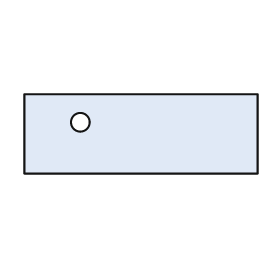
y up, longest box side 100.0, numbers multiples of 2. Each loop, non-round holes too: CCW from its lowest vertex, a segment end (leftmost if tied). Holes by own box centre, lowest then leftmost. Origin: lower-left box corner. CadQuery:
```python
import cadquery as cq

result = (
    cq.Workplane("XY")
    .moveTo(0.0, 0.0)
    .lineTo(100.0, 0.0)
    .lineTo(100.0, 34.0)
    .lineTo(0.0, 34.0)
    .close()
    .moveTo(24.0, 22.0)
    .circle(4.0)
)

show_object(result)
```